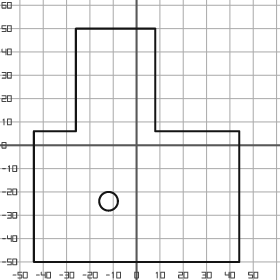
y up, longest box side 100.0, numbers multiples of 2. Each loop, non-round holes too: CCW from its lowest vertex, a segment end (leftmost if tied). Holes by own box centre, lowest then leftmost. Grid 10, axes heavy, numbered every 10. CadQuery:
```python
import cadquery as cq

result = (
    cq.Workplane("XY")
    .moveTo(-44.0, -50.0)
    .lineTo(44.0, -50.0)
    .lineTo(44.0, 6.0)
    .lineTo(8.0, 6.0)
    .lineTo(8.0, 50.0)
    .lineTo(-26.0, 50.0)
    .lineTo(-26.0, 6.0)
    .lineTo(-44.0, 6.0)
    .close()
    .moveTo(-12.0, -24.0)
    .circle(4.0)
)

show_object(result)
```